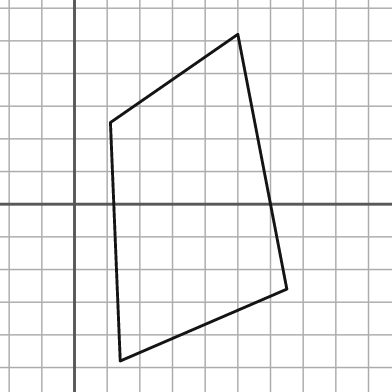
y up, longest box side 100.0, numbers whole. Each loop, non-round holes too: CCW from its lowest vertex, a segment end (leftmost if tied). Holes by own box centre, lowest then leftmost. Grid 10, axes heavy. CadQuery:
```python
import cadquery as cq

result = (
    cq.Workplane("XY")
    .moveTo(14.0, -48.0)
    .lineTo(65.0, -26.0)
    .lineTo(50.0, 52.0)
    .lineTo(11.0, 25.0)
    .close()
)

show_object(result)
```